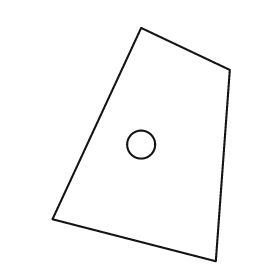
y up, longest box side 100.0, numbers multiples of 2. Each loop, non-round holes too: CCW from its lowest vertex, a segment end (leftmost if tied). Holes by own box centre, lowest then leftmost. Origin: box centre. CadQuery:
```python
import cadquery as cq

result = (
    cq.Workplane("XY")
    .moveTo(32.0, -50.0)
    .lineTo(38.0, 32.0)
    .lineTo(0.0, 50.0)
    .lineTo(-38.0, -32.0)
    .close()
    .moveTo(0.0, 0.0)
    .circle(6.0)
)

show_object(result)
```